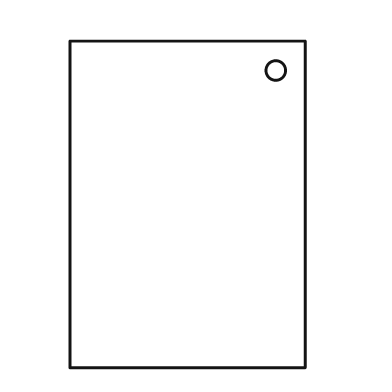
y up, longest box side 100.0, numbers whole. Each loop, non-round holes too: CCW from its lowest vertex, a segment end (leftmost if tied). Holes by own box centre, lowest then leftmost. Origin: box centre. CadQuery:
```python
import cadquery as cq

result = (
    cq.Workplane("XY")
    .moveTo(-36.0, -50.0)
    .lineTo(36.0, -50.0)
    .lineTo(36.0, 50.0)
    .lineTo(-36.0, 50.0)
    .close()
    .moveTo(27.0, 41.0)
    .circle(3.0)
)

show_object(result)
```